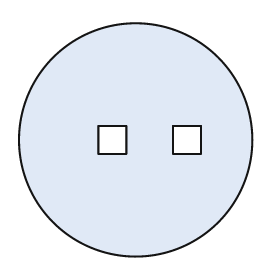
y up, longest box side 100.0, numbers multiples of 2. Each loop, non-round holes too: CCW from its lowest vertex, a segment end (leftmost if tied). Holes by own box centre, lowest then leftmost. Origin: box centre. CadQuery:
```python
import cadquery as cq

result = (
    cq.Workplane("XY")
    .moveTo(0.0, 0.0)
    .circle(50.0)
    .moveTo(-16.0, -6.0)
    .lineTo(-4.0, -6.0)
    .lineTo(-4.0, 6.0)
    .lineTo(-16.0, 6.0)
    .close()
    .moveTo(16.0, -6.0)
    .lineTo(28.0, -6.0)
    .lineTo(28.0, 6.0)
    .lineTo(16.0, 6.0)
    .close()
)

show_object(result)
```